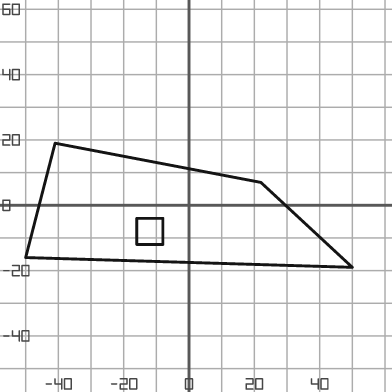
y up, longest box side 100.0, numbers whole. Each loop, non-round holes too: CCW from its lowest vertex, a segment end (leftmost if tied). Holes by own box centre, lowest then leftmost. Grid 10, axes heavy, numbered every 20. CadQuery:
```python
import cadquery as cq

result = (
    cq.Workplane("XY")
    .moveTo(50.0, -19.0)
    .lineTo(22.0, 7.0)
    .lineTo(-41.0, 19.0)
    .lineTo(-50.0, -16.0)
    .close()
    .moveTo(-16.0, -12.0)
    .lineTo(-8.0, -12.0)
    .lineTo(-8.0, -4.0)
    .lineTo(-16.0, -4.0)
    .close()
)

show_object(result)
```